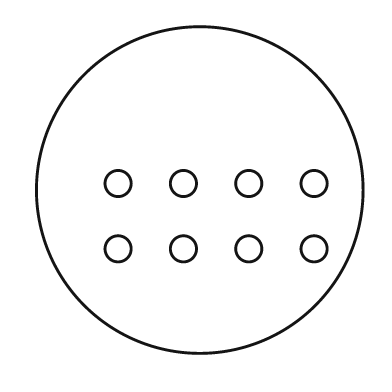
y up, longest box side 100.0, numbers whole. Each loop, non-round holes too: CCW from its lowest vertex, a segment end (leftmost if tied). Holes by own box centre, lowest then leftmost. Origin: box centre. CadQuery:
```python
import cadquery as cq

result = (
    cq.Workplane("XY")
    .moveTo(0.0, 0.0)
    .circle(50.0)
    .moveTo(-25.0, -18.0)
    .circle(4.0)
    .moveTo(-5.0, -18.0)
    .circle(4.0)
    .moveTo(15.0, -18.0)
    .circle(4.0)
    .moveTo(35.0, -18.0)
    .circle(4.0)
    .moveTo(-25.0, 2.0)
    .circle(4.0)
    .moveTo(-5.0, 2.0)
    .circle(4.0)
    .moveTo(15.0, 2.0)
    .circle(4.0)
    .moveTo(35.0, 2.0)
    .circle(4.0)
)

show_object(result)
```